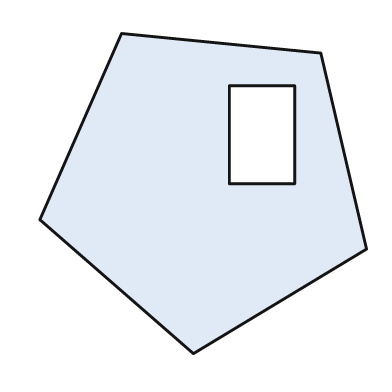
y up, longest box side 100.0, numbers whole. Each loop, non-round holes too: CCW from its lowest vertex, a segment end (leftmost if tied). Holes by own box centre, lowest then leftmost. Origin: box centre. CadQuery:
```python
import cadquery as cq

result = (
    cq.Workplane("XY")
    .moveTo(-3.0, -49.0)
    .lineTo(50.0, -17.0)
    .lineTo(36.0, 43.0)
    .lineTo(-25.0, 49.0)
    .lineTo(-50.0, -8.0)
    .close()
    .moveTo(8.0, 3.0)
    .lineTo(28.0, 3.0)
    .lineTo(28.0, 33.0)
    .lineTo(8.0, 33.0)
    .close()
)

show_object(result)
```